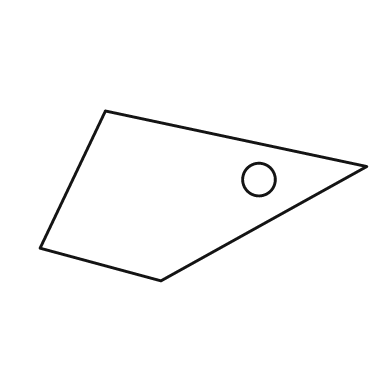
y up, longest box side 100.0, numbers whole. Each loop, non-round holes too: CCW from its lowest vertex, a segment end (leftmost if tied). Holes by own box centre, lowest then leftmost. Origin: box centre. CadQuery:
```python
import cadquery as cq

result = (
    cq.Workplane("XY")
    .moveTo(-13.0, -26.0)
    .lineTo(50.0, 9.0)
    .lineTo(-30.0, 26.0)
    .lineTo(-50.0, -16.0)
    .close()
    .moveTo(17.0, 5.0)
    .circle(5.0)
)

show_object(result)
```